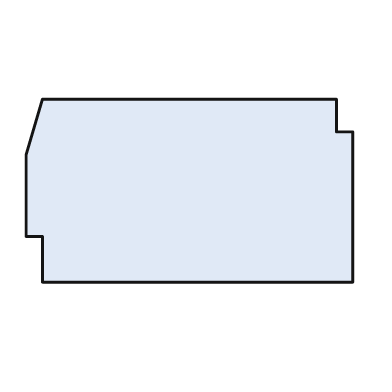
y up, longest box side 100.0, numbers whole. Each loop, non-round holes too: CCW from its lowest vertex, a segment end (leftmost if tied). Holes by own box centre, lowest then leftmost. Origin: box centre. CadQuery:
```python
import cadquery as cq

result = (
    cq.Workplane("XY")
    .moveTo(-45.0, -28.0)
    .lineTo(50.0, -28.0)
    .lineTo(50.0, 18.0)
    .lineTo(45.0, 18.0)
    .lineTo(45.0, 28.0)
    .lineTo(-45.0, 28.0)
    .lineTo(-50.0, 11.0)
    .lineTo(-50.0, -14.0)
    .lineTo(-45.0, -14.0)
    .close()
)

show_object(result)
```